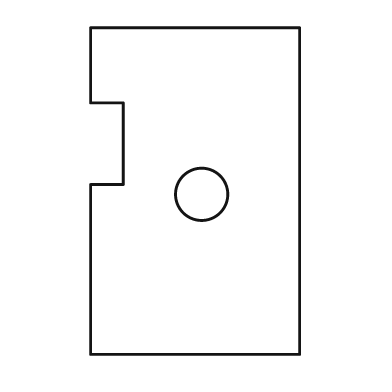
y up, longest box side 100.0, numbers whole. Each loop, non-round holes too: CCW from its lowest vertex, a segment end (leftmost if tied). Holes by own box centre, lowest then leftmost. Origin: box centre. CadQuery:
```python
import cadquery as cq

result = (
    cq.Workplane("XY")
    .moveTo(-32.0, -50.0)
    .lineTo(32.0, -50.0)
    .lineTo(32.0, 50.0)
    .lineTo(-32.0, 50.0)
    .lineTo(-32.0, 27.0)
    .lineTo(-22.0, 27.0)
    .lineTo(-22.0, 2.0)
    .lineTo(-32.0, 2.0)
    .close()
    .moveTo(2.0, -1.0)
    .circle(8.0)
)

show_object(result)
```